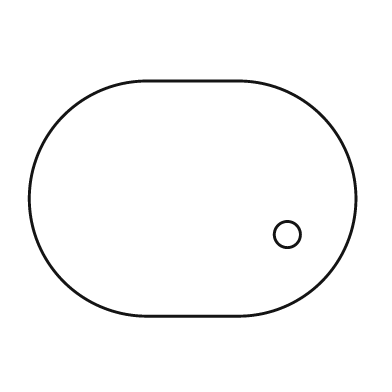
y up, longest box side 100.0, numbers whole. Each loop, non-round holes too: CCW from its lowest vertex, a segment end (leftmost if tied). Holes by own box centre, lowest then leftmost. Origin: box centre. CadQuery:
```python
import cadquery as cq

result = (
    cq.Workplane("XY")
    .moveTo(-14.0, -36.0)
    .lineTo(14.0, -36.0)
    .threePointArc((50.0, 0.0), (14.0, 36.0))
    .lineTo(-14.0, 36.0)
    .threePointArc((-50.0, 0.0), (-14.0, -36.0))
    .close()
    .moveTo(29.0, -11.0)
    .circle(4.0)
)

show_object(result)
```